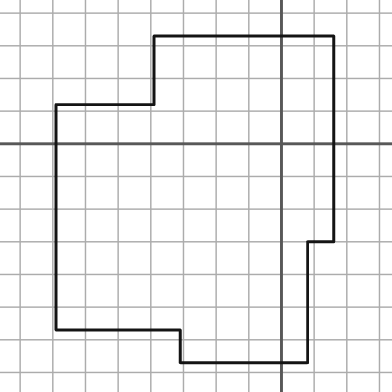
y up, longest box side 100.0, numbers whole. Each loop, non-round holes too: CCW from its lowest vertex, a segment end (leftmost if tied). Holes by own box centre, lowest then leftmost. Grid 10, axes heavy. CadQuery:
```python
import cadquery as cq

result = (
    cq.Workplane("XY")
    .moveTo(-31.0, -67.0)
    .lineTo(8.0, -67.0)
    .lineTo(8.0, -30.0)
    .lineTo(16.0, -30.0)
    .lineTo(16.0, 33.0)
    .lineTo(-39.0, 33.0)
    .lineTo(-39.0, 12.0)
    .lineTo(-69.0, 12.0)
    .lineTo(-69.0, -57.0)
    .lineTo(-31.0, -57.0)
    .close()
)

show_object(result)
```